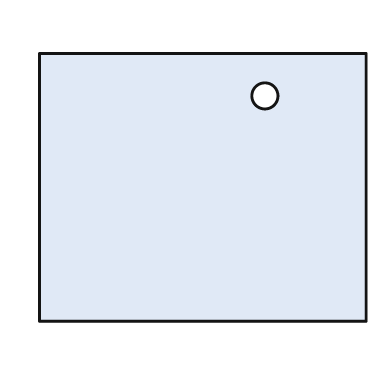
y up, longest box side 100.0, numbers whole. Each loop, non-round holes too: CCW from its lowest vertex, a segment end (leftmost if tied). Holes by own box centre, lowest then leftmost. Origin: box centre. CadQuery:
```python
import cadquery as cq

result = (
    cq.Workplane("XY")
    .moveTo(-50.0, -41.0)
    .lineTo(50.0, -41.0)
    .lineTo(50.0, 41.0)
    .lineTo(-50.0, 41.0)
    .close()
    .moveTo(19.0, 28.0)
    .circle(4.0)
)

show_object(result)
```